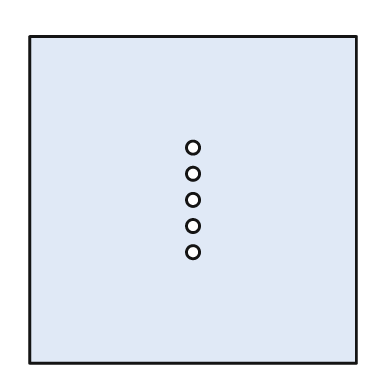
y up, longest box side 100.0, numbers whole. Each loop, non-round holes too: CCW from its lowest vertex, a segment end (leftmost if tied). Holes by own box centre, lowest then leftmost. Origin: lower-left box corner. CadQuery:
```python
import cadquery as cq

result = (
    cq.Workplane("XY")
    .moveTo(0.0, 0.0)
    .lineTo(100.0, 0.0)
    .lineTo(100.0, 100.0)
    .lineTo(0.0, 100.0)
    .close()
    .moveTo(50.0, 34.0)
    .circle(2.0)
    .moveTo(50.0, 42.0)
    .circle(2.0)
    .moveTo(50.0, 50.0)
    .circle(2.0)
    .moveTo(50.0, 58.0)
    .circle(2.0)
    .moveTo(50.0, 66.0)
    .circle(2.0)
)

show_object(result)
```